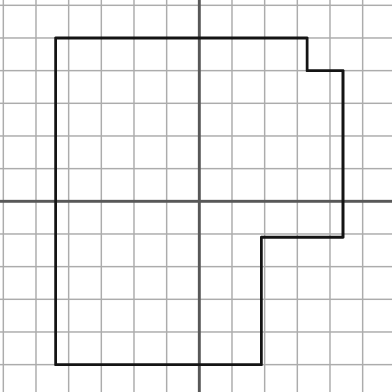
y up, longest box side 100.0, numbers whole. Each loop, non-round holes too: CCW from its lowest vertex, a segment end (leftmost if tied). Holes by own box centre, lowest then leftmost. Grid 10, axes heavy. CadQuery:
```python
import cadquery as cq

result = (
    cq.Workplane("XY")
    .moveTo(-44.0, -50.0)
    .lineTo(19.0, -50.0)
    .lineTo(19.0, -11.0)
    .lineTo(44.0, -11.0)
    .lineTo(44.0, 40.0)
    .lineTo(33.0, 40.0)
    .lineTo(33.0, 50.0)
    .lineTo(-44.0, 50.0)
    .close()
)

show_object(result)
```